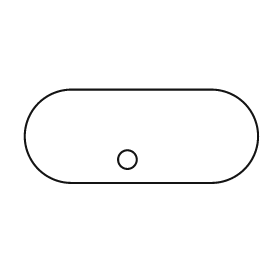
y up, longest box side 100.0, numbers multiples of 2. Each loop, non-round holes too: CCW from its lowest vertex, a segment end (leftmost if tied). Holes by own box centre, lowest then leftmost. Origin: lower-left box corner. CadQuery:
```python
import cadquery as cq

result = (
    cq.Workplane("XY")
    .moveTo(20.0, 0.0)
    .lineTo(80.0, 0.0)
    .threePointArc((100.0, 20.0), (80.0, 40.0))
    .lineTo(20.0, 40.0)
    .threePointArc((0.0, 20.0), (20.0, 0.0))
    .close()
    .moveTo(44.0, 10.0)
    .circle(4.0)
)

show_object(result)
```